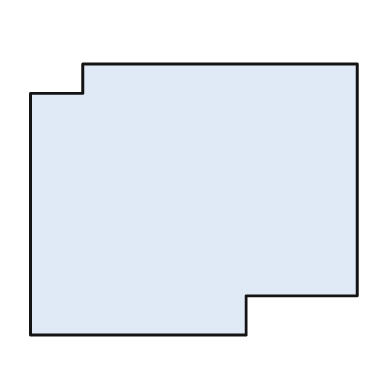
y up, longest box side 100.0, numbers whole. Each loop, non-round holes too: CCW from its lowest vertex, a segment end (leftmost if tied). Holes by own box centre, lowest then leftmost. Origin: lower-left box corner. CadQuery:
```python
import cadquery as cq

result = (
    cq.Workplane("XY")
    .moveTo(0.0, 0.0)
    .lineTo(66.0, 0.0)
    .lineTo(66.0, 12.0)
    .lineTo(100.0, 12.0)
    .lineTo(100.0, 83.0)
    .lineTo(16.0, 83.0)
    .lineTo(16.0, 74.0)
    .lineTo(0.0, 74.0)
    .close()
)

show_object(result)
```